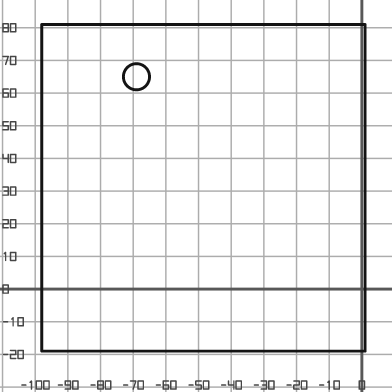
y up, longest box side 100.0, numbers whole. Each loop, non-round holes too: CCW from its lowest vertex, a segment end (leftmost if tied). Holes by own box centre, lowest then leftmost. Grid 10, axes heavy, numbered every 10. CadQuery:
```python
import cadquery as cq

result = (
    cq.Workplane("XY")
    .moveTo(-98.0, -19.0)
    .lineTo(1.0, -19.0)
    .lineTo(1.0, 81.0)
    .lineTo(-98.0, 81.0)
    .close()
    .moveTo(-69.0, 65.0)
    .circle(4.0)
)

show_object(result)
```